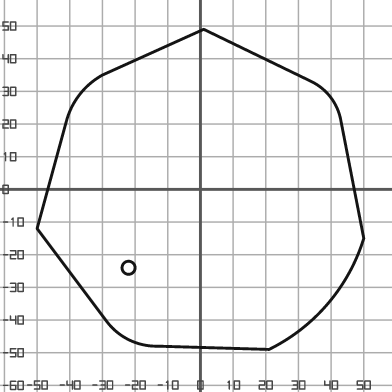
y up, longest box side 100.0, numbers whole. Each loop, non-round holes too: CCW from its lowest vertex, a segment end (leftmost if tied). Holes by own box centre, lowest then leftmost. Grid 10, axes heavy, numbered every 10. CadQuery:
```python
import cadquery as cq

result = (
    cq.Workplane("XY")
    .moveTo(21.0, -49.0)
    .threePointArc((39.0, -35.0), (50.0, -15.0))
    .lineTo(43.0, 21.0)
    .threePointArc((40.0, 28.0), (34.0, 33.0))
    .lineTo(1.0, 49.0)
    .lineTo(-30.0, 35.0)
    .threePointArc((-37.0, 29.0), (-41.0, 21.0))
    .lineTo(-50.0, -12.0)
    .lineTo(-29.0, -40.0)
    .threePointArc((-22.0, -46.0), (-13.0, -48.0))
    .close()
    .moveTo(-22.0, -24.0)
    .circle(2.0)
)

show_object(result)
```